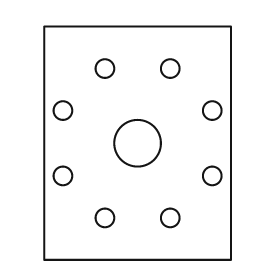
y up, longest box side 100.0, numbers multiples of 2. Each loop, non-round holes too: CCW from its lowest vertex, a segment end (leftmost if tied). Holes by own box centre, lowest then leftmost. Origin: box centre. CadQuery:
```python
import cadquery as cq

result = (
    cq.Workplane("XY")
    .moveTo(-40.0, -50.0)
    .lineTo(40.0, -50.0)
    .lineTo(40.0, 50.0)
    .lineTo(-40.0, 50.0)
    .close()
    .moveTo(-14.0, -32.0)
    .circle(4.0)
    .moveTo(14.0, -32.0)
    .circle(4.0)
    .moveTo(-32.0, -14.0)
    .circle(4.0)
    .moveTo(32.0, -14.0)
    .circle(4.0)
    .moveTo(0.0, 0.0)
    .circle(10.0)
    .moveTo(-32.0, 14.0)
    .circle(4.0)
    .moveTo(32.0, 14.0)
    .circle(4.0)
    .moveTo(-14.0, 32.0)
    .circle(4.0)
    .moveTo(14.0, 32.0)
    .circle(4.0)
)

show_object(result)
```